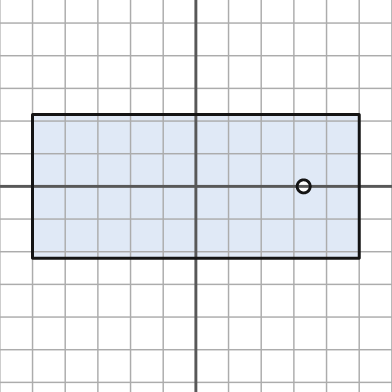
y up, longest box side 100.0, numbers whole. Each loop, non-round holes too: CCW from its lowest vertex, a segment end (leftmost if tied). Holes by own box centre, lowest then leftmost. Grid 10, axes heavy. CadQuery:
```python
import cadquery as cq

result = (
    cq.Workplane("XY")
    .moveTo(-50.0, -22.0)
    .lineTo(50.0, -22.0)
    .lineTo(50.0, 22.0)
    .lineTo(-50.0, 22.0)
    .close()
    .moveTo(33.0, 0.0)
    .circle(2.0)
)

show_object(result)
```